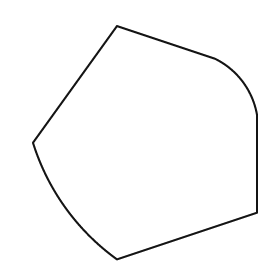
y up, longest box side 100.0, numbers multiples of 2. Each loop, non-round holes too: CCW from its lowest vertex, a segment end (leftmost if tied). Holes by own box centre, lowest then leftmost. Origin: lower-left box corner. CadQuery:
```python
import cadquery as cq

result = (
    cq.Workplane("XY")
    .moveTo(36.0, 0.0)
    .lineTo(96.0, 20.0)
    .lineTo(96.0, 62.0)
    .threePointArc((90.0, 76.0), (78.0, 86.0))
    .lineTo(36.0, 100.0)
    .lineTo(0.0, 50.0)
    .threePointArc((14.0, 22.0), (36.0, 0.0))
    .close()
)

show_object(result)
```